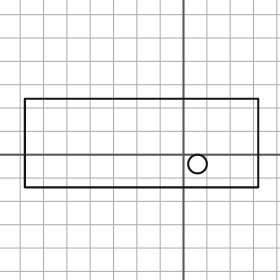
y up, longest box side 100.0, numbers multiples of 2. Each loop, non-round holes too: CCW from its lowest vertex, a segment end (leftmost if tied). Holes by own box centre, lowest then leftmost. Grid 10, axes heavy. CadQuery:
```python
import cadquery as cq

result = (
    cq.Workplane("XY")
    .moveTo(-68.0, -14.0)
    .lineTo(32.0, -14.0)
    .lineTo(32.0, 24.0)
    .lineTo(-68.0, 24.0)
    .close()
    .moveTo(6.0, -4.0)
    .circle(4.0)
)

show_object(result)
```